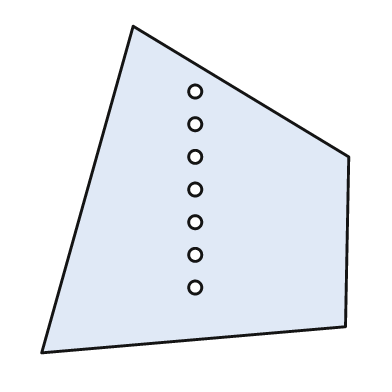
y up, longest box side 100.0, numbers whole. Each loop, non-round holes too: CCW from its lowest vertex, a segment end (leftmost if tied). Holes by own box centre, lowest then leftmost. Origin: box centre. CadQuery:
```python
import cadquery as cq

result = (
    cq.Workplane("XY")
    .moveTo(-47.0, -50.0)
    .lineTo(46.0, -42.0)
    .lineTo(47.0, 10.0)
    .lineTo(-19.0, 50.0)
    .close()
    .moveTo(0.0, -30.0)
    .circle(2.0)
    .moveTo(0.0, -20.0)
    .circle(2.0)
    .moveTo(0.0, -10.0)
    .circle(2.0)
    .moveTo(0.0, 0.0)
    .circle(2.0)
    .moveTo(0.0, 10.0)
    .circle(2.0)
    .moveTo(0.0, 20.0)
    .circle(2.0)
    .moveTo(0.0, 30.0)
    .circle(2.0)
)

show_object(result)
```